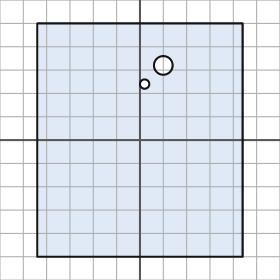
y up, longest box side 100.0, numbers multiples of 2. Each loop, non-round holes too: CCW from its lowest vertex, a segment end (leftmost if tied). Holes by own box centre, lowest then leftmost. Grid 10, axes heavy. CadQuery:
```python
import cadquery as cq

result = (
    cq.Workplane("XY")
    .moveTo(-44.0, -50.0)
    .lineTo(44.0, -50.0)
    .lineTo(44.0, 50.0)
    .lineTo(-44.0, 50.0)
    .close()
    .moveTo(2.0, 24.0)
    .circle(2.0)
    .moveTo(10.0, 32.0)
    .circle(4.0)
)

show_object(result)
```